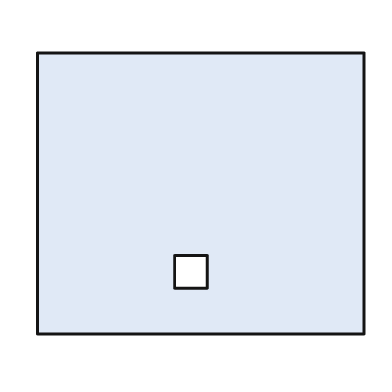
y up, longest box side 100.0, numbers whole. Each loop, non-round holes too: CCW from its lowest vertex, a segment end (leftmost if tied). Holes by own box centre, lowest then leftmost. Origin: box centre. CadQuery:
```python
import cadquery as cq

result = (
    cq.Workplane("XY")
    .moveTo(-50.0, -43.0)
    .lineTo(50.0, -43.0)
    .lineTo(50.0, 43.0)
    .lineTo(-50.0, 43.0)
    .close()
    .moveTo(-8.0, -29.0)
    .lineTo(2.0, -29.0)
    .lineTo(2.0, -19.0)
    .lineTo(-8.0, -19.0)
    .close()
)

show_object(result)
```